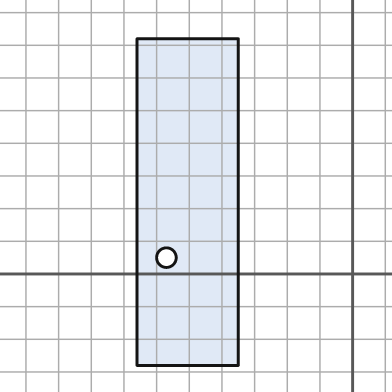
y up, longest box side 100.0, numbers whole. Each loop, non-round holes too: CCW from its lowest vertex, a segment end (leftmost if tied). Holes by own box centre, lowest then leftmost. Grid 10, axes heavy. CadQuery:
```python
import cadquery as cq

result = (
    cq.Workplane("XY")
    .moveTo(-66.0, -28.0)
    .lineTo(-35.0, -28.0)
    .lineTo(-35.0, 72.0)
    .lineTo(-66.0, 72.0)
    .close()
    .moveTo(-57.0, 5.0)
    .circle(3.0)
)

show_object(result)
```